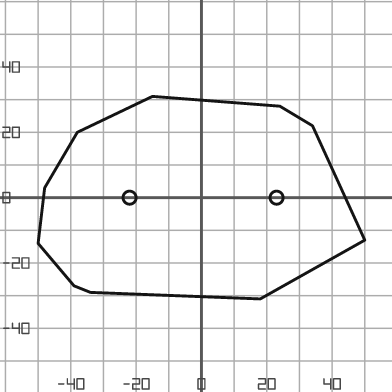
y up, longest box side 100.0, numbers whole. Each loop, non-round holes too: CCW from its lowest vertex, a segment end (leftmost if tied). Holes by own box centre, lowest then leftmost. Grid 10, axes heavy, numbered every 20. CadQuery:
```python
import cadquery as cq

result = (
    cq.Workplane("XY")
    .moveTo(18.0, -31.0)
    .lineTo(50.0, -13.0)
    .lineTo(34.0, 22.0)
    .lineTo(24.0, 28.0)
    .lineTo(-15.0, 31.0)
    .lineTo(-38.0, 20.0)
    .lineTo(-48.0, 3.0)
    .lineTo(-50.0, -14.0)
    .lineTo(-39.0, -27.0)
    .lineTo(-34.0, -29.0)
    .close()
    .moveTo(-22.0, 0.0)
    .circle(2.0)
    .moveTo(23.0, 0.0)
    .circle(2.0)
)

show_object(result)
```